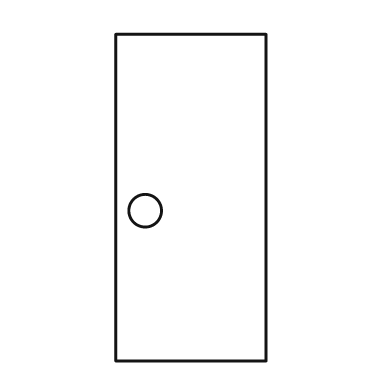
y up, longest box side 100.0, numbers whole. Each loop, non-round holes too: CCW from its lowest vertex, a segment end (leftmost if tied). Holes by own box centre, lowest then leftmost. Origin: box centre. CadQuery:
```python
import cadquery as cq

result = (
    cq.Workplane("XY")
    .moveTo(-23.0, -50.0)
    .lineTo(23.0, -50.0)
    .lineTo(23.0, 50.0)
    .lineTo(-23.0, 50.0)
    .close()
    .moveTo(-14.0, -4.0)
    .circle(5.0)
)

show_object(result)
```